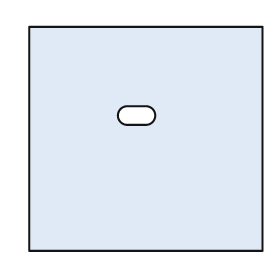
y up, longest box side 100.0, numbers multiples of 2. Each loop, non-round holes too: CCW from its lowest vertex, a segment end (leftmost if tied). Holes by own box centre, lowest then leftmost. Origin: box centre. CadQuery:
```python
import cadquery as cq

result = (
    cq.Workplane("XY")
    .moveTo(-50.0, -48.0)
    .lineTo(50.0, -48.0)
    .lineTo(50.0, 48.0)
    .lineTo(-50.0, 48.0)
    .close()
    .moveTo(-8.0, 6.0)
    .lineTo(0.0, 6.0)
    .threePointArc((4.0, 10.0), (0.0, 14.0))
    .lineTo(-8.0, 14.0)
    .threePointArc((-12.0, 10.0), (-8.0, 6.0))
    .close()
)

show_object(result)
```